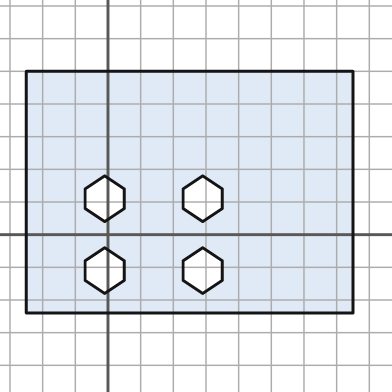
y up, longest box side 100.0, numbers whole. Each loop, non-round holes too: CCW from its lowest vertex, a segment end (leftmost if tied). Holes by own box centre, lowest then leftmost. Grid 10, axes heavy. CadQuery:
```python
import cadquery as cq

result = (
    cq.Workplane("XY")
    .moveTo(-25.0, -24.0)
    .lineTo(75.0, -24.0)
    .lineTo(75.0, 50.0)
    .lineTo(-25.0, 50.0)
    .close()
    .moveTo(-1.0, -18.0)
    .lineTo(5.0, -14.0)
    .lineTo(5.0, -8.0)
    .lineTo(-1.0, -4.0)
    .lineTo(-7.0, -8.0)
    .lineTo(-7.0, -14.0)
    .close()
    .moveTo(29.0, -18.0)
    .lineTo(35.0, -14.0)
    .lineTo(35.0, -8.0)
    .lineTo(29.0, -4.0)
    .lineTo(23.0, -8.0)
    .lineTo(23.0, -14.0)
    .close()
    .moveTo(-1.0, 4.0)
    .lineTo(5.0, 8.0)
    .lineTo(5.0, 14.0)
    .lineTo(-1.0, 18.0)
    .lineTo(-7.0, 14.0)
    .lineTo(-7.0, 8.0)
    .close()
    .moveTo(29.0, 4.0)
    .lineTo(35.0, 8.0)
    .lineTo(35.0, 14.0)
    .lineTo(29.0, 18.0)
    .lineTo(23.0, 14.0)
    .lineTo(23.0, 8.0)
    .close()
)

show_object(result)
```